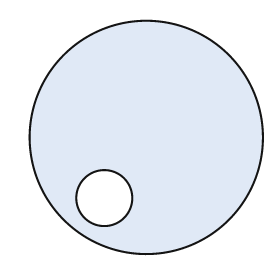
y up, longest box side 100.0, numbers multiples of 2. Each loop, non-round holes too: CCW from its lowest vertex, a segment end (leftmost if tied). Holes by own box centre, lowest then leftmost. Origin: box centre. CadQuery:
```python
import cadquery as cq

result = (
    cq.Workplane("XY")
    .moveTo(0.0, 0.0)
    .circle(50.0)
    .moveTo(-18.0, -26.0)
    .circle(12.0)
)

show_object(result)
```